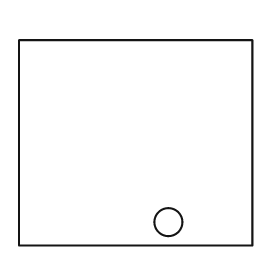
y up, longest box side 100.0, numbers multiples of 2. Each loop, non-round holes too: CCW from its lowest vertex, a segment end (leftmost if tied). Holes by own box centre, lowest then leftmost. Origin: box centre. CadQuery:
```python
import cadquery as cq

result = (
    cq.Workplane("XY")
    .moveTo(-50.0, -44.0)
    .lineTo(50.0, -44.0)
    .lineTo(50.0, 44.0)
    .lineTo(-50.0, 44.0)
    .close()
    .moveTo(14.0, -34.0)
    .circle(6.0)
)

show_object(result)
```